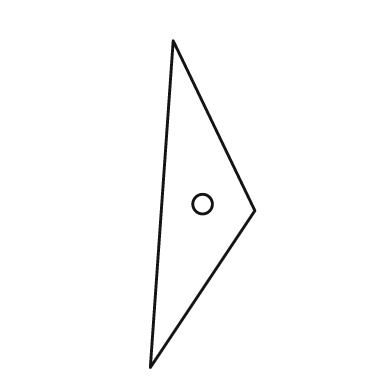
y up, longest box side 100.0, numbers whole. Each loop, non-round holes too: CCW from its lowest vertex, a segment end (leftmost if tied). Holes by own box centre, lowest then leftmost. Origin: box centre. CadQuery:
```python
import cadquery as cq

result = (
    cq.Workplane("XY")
    .moveTo(-16.0, -50.0)
    .lineTo(16.0, -2.0)
    .lineTo(-9.0, 50.0)
    .close()
    .moveTo(0.0, 0.0)
    .circle(3.0)
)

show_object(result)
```